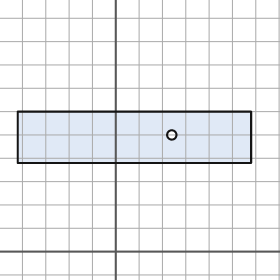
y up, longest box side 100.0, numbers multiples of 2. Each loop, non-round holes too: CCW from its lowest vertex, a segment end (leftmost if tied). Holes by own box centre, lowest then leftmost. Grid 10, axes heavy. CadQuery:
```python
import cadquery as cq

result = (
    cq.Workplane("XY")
    .moveTo(-42.0, 38.0)
    .lineTo(58.0, 38.0)
    .lineTo(58.0, 60.0)
    .lineTo(-42.0, 60.0)
    .close()
    .moveTo(24.0, 50.0)
    .circle(2.0)
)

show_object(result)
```